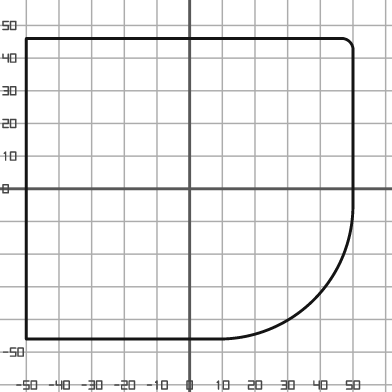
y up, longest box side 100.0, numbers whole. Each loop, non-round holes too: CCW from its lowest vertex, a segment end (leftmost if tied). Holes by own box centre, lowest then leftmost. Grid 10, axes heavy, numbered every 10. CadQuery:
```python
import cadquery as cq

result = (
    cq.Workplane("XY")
    .moveTo(-50.0, -46.0)
    .lineTo(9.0, -46.0)
    .threePointArc((38.0, -34.0), (50.0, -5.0))
    .lineTo(50.0, 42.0)
    .threePointArc((49.0, 45.0), (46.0, 46.0))
    .lineTo(-50.0, 46.0)
    .close()
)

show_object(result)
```